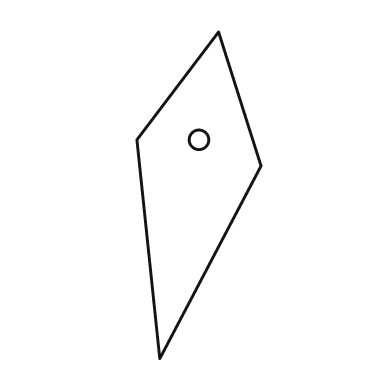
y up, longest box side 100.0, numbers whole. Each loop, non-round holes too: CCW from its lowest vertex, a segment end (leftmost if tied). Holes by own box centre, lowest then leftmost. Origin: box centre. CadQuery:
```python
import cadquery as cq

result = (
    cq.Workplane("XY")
    .moveTo(-12.0, -50.0)
    .lineTo(19.0, 9.0)
    .lineTo(6.0, 50.0)
    .lineTo(-19.0, 17.0)
    .close()
    .moveTo(0.0, 17.0)
    .circle(3.0)
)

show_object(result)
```